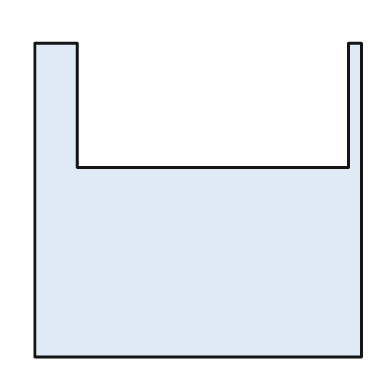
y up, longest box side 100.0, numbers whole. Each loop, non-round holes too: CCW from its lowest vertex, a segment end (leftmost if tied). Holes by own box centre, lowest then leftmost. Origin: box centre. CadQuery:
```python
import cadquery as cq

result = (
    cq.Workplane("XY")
    .moveTo(-50.0, -48.0)
    .lineTo(50.0, -48.0)
    .lineTo(50.0, 48.0)
    .lineTo(46.0, 48.0)
    .lineTo(46.0, 10.0)
    .lineTo(-37.0, 10.0)
    .lineTo(-37.0, 48.0)
    .lineTo(-50.0, 48.0)
    .close()
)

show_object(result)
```